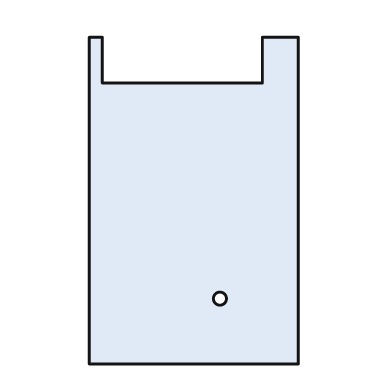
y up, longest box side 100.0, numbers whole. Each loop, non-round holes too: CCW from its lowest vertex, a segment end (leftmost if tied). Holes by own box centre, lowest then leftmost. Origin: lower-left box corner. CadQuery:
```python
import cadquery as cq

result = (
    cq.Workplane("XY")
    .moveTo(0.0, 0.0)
    .lineTo(64.0, 0.0)
    .lineTo(64.0, 100.0)
    .lineTo(53.0, 100.0)
    .lineTo(53.0, 86.0)
    .lineTo(4.0, 86.0)
    .lineTo(4.0, 100.0)
    .lineTo(0.0, 100.0)
    .close()
    .moveTo(40.0, 20.0)
    .circle(2.0)
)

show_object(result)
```